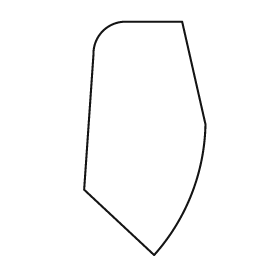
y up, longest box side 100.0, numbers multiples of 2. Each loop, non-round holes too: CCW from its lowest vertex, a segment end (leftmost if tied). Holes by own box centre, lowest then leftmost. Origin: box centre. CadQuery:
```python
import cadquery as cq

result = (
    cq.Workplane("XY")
    .moveTo(4.0, -50.0)
    .threePointArc((20.0, -24.0), (26.0, 6.0))
    .lineTo(16.0, 50.0)
    .lineTo(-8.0, 50.0)
    .threePointArc((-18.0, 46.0), (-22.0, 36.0))
    .lineTo(-26.0, -22.0)
    .close()
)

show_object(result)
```